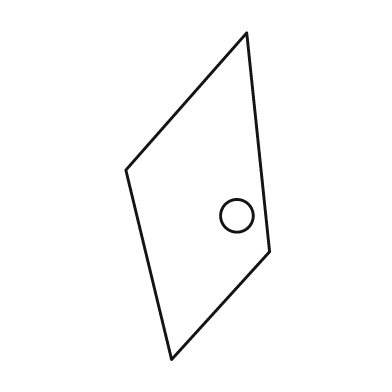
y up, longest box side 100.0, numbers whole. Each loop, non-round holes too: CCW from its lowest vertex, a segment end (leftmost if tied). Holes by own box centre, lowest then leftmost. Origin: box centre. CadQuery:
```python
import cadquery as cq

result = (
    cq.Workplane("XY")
    .moveTo(-8.0, -50.0)
    .lineTo(22.0, -17.0)
    .lineTo(15.0, 50.0)
    .lineTo(-22.0, 8.0)
    .close()
    .moveTo(12.0, -6.0)
    .circle(5.0)
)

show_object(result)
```